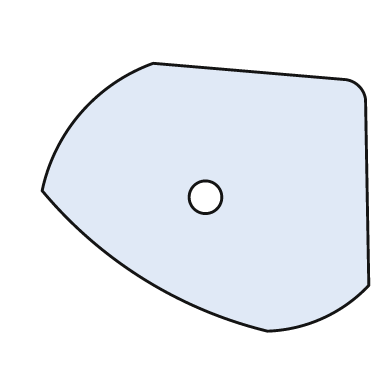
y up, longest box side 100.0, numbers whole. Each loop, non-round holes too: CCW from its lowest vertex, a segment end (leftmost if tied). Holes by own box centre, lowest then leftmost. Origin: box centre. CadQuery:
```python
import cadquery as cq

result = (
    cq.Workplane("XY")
    .moveTo(19.0, -41.0)
    .threePointArc((36.0, -37.0), (50.0, -27.0))
    .lineTo(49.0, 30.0)
    .threePointArc((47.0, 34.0), (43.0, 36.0))
    .lineTo(-16.0, 41.0)
    .threePointArc((-38.0, 26.0), (-50.0, 2.0))
    .threePointArc((-19.0, -25.0), (19.0, -41.0))
    .close()
    .moveTo(0.0, 0.0)
    .circle(5.0)
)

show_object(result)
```